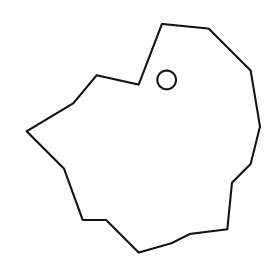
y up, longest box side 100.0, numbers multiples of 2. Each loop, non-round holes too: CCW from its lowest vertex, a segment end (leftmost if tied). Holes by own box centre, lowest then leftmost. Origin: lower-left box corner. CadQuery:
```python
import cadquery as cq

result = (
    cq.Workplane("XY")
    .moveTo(48.0, 0.0)
    .lineTo(62.0, 4.0)
    .lineTo(70.0, 8.0)
    .lineTo(86.0, 10.0)
    .lineTo(88.0, 30.0)
    .lineTo(96.0, 38.0)
    .lineTo(100.0, 54.0)
    .lineTo(96.0, 78.0)
    .lineTo(78.0, 96.0)
    .lineTo(58.0, 98.0)
    .lineTo(48.0, 72.0)
    .lineTo(30.0, 76.0)
    .lineTo(20.0, 64.0)
    .lineTo(0.0, 52.0)
    .lineTo(16.0, 36.0)
    .lineTo(24.0, 14.0)
    .lineTo(34.0, 14.0)
    .close()
    .moveTo(60.0, 74.0)
    .circle(4.0)
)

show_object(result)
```